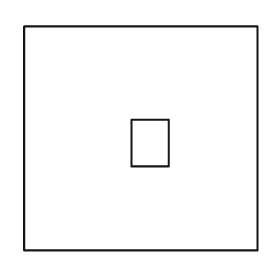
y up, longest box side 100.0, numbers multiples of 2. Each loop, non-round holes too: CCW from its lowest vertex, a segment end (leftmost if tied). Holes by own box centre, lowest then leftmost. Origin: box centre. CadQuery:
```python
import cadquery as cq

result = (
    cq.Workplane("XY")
    .moveTo(-50.0, -48.0)
    .lineTo(50.0, -48.0)
    .lineTo(50.0, 48.0)
    .lineTo(-50.0, 48.0)
    .close()
    .moveTo(-4.0, -12.0)
    .lineTo(12.0, -12.0)
    .lineTo(12.0, 8.0)
    .lineTo(-4.0, 8.0)
    .close()
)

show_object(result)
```